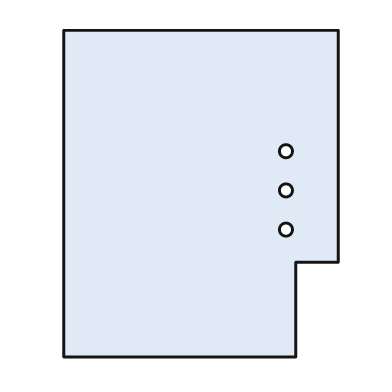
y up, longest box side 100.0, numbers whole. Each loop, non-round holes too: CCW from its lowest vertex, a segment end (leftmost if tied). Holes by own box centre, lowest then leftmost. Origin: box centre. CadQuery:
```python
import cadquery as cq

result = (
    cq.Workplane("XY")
    .moveTo(-42.0, -50.0)
    .lineTo(29.0, -50.0)
    .lineTo(29.0, -21.0)
    .lineTo(42.0, -21.0)
    .lineTo(42.0, 50.0)
    .lineTo(-42.0, 50.0)
    .close()
    .moveTo(26.0, -11.0)
    .circle(2.0)
    .moveTo(26.0, 1.0)
    .circle(2.0)
    .moveTo(26.0, 13.0)
    .circle(2.0)
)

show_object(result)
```